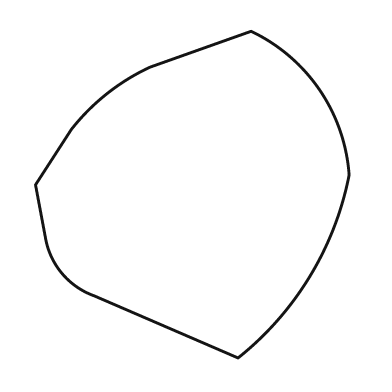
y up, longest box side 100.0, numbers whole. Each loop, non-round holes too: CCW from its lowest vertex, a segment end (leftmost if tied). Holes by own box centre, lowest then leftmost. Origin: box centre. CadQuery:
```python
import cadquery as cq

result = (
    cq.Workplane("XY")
    .moveTo(14.0, -50.0)
    .threePointArc((36.0, -25.0), (48.0, 6.0))
    .threePointArc((39.0, 32.0), (18.0, 50.0))
    .lineTo(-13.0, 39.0)
    .threePointArc((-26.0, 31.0), (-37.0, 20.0))
    .lineTo(-48.0, 3.0)
    .lineTo(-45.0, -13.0)
    .threePointArc((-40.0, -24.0), (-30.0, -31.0))
    .close()
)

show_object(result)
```